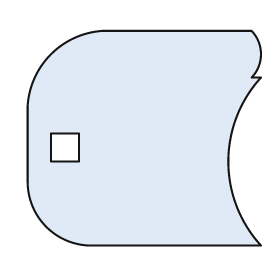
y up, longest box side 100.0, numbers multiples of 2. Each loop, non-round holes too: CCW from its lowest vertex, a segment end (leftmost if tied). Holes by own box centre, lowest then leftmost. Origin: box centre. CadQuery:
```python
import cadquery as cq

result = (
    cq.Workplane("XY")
    .moveTo(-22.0, -46.0)
    .lineTo(50.0, -46.0)
    .threePointArc((36.0, -10.0), (50.0, 26.0))
    .lineTo(46.0, 26.0)
    .threePointArc((50.0, 36.0), (46.0, 46.0))
    .lineTo(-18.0, 46.0)
    .threePointArc((-40.0, 36.0), (-50.0, 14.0))
    .lineTo(-50.0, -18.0)
    .threePointArc((-42.0, -38.0), (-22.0, -46.0))
    .close()
    .moveTo(-40.0, -10.0)
    .lineTo(-28.0, -10.0)
    .lineTo(-28.0, 2.0)
    .lineTo(-40.0, 2.0)
    .close()
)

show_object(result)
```